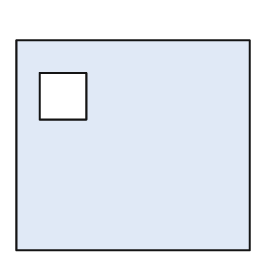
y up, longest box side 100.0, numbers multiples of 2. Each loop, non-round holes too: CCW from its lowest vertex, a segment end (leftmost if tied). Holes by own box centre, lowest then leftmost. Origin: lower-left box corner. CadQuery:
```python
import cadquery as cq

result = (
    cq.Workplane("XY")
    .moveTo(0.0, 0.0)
    .lineTo(100.0, 0.0)
    .lineTo(100.0, 90.0)
    .lineTo(0.0, 90.0)
    .close()
    .moveTo(10.0, 56.0)
    .lineTo(30.0, 56.0)
    .lineTo(30.0, 76.0)
    .lineTo(10.0, 76.0)
    .close()
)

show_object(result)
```